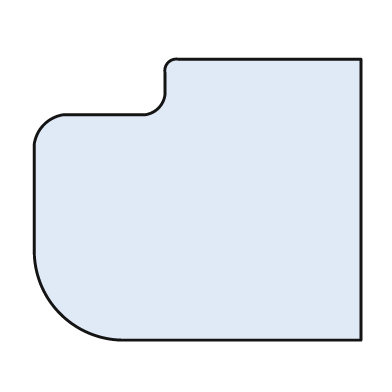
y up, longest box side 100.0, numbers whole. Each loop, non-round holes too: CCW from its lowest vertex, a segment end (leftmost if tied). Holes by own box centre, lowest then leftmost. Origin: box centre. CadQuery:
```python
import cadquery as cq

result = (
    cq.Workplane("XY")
    .moveTo(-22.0, -43.0)
    .lineTo(50.0, -43.0)
    .lineTo(50.0, 43.0)
    .lineTo(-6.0, 43.0)
    .threePointArc((-9.0, 42.0), (-10.0, 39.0))
    .lineTo(-10.0, 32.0)
    .threePointArc((-12.0, 28.0), (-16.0, 26.0))
    .lineTo(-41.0, 26.0)
    .threePointArc((-47.0, 23.0), (-50.0, 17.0))
    .lineTo(-50.0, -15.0)
    .threePointArc((-42.0, -35.0), (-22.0, -43.0))
    .close()
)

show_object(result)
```